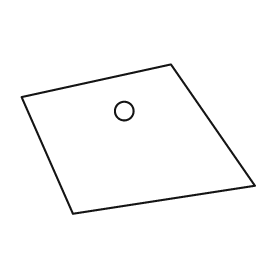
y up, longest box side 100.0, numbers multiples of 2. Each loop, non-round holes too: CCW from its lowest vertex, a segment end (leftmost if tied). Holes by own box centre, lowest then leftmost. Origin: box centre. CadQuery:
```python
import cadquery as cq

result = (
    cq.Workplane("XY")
    .moveTo(-28.0, -32.0)
    .lineTo(50.0, -20.0)
    .lineTo(14.0, 32.0)
    .lineTo(-50.0, 18.0)
    .close()
    .moveTo(-6.0, 12.0)
    .circle(4.0)
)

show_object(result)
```